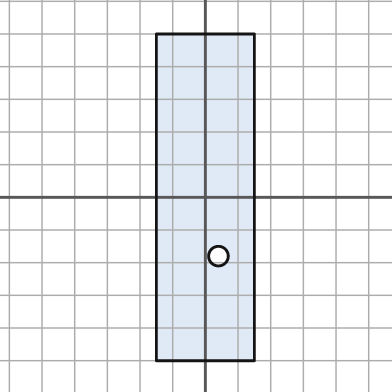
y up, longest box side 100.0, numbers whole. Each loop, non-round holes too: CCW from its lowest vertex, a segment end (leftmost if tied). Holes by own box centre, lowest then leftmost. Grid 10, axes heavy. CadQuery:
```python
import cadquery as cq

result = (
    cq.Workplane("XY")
    .moveTo(-15.0, -50.0)
    .lineTo(15.0, -50.0)
    .lineTo(15.0, 50.0)
    .lineTo(-15.0, 50.0)
    .close()
    .moveTo(4.0, -18.0)
    .circle(3.0)
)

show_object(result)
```